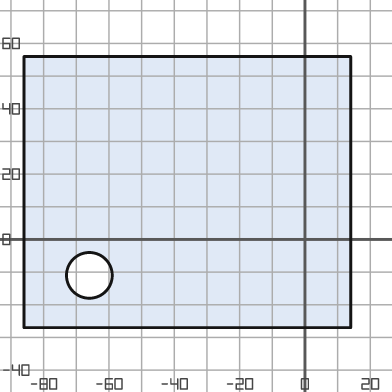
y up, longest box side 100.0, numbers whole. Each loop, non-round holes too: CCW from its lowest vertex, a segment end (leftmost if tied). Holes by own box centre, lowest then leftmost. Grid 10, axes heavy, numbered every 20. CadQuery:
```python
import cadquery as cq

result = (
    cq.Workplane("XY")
    .moveTo(-86.0, -27.0)
    .lineTo(14.0, -27.0)
    .lineTo(14.0, 56.0)
    .lineTo(-86.0, 56.0)
    .close()
    .moveTo(-66.0, -11.0)
    .circle(7.0)
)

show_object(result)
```